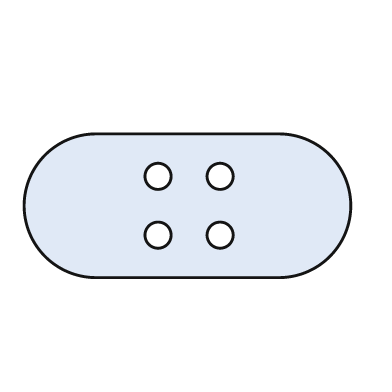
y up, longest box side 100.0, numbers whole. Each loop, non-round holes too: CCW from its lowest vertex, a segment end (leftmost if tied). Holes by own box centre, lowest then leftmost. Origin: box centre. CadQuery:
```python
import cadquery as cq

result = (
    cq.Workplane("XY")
    .moveTo(-28.0, -22.0)
    .lineTo(28.0, -22.0)
    .threePointArc((50.0, 0.0), (28.0, 22.0))
    .lineTo(-28.0, 22.0)
    .threePointArc((-50.0, 0.0), (-28.0, -22.0))
    .close()
    .moveTo(-9.0, -9.0)
    .circle(4.0)
    .moveTo(10.0, -9.0)
    .circle(4.0)
    .moveTo(-9.0, 9.0)
    .circle(4.0)
    .moveTo(10.0, 9.0)
    .circle(4.0)
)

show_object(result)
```